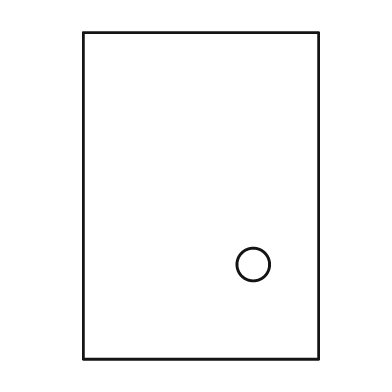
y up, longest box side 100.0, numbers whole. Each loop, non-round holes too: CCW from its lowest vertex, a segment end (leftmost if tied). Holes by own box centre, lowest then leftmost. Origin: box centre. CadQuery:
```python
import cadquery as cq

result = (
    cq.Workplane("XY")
    .moveTo(-36.0, -50.0)
    .lineTo(36.0, -50.0)
    .lineTo(36.0, 50.0)
    .lineTo(-36.0, 50.0)
    .close()
    .moveTo(16.0, -21.0)
    .circle(5.0)
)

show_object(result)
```